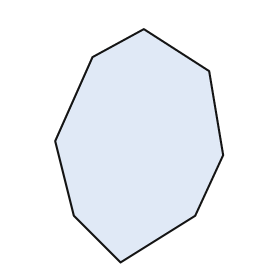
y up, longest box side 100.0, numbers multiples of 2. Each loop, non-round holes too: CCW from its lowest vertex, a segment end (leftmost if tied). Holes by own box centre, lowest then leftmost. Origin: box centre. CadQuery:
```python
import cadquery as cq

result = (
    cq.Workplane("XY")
    .moveTo(-8.0, -50.0)
    .lineTo(24.0, -30.0)
    .lineTo(36.0, -4.0)
    .lineTo(30.0, 32.0)
    .lineTo(2.0, 50.0)
    .lineTo(-20.0, 38.0)
    .lineTo(-36.0, 2.0)
    .lineTo(-28.0, -30.0)
    .close()
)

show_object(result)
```